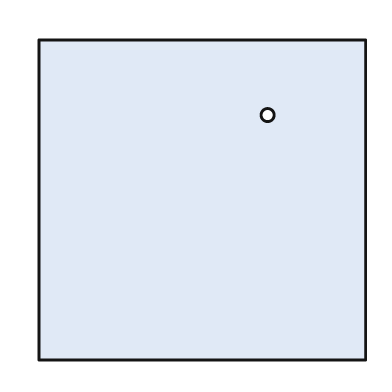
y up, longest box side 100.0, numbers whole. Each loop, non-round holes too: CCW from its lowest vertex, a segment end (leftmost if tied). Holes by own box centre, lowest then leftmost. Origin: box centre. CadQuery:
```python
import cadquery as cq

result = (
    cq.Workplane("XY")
    .moveTo(-50.0, -49.0)
    .lineTo(50.0, -49.0)
    .lineTo(50.0, 49.0)
    .lineTo(-50.0, 49.0)
    .close()
    .moveTo(20.0, 26.0)
    .circle(2.0)
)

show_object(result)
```